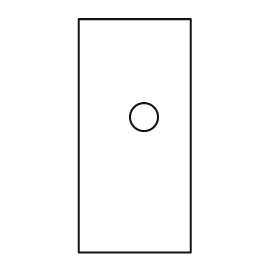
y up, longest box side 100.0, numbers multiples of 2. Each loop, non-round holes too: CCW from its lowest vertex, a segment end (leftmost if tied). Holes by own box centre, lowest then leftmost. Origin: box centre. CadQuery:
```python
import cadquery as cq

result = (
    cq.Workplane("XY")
    .moveTo(-24.0, -50.0)
    .lineTo(24.0, -50.0)
    .lineTo(24.0, 50.0)
    .lineTo(-24.0, 50.0)
    .close()
    .moveTo(4.0, 8.0)
    .circle(6.0)
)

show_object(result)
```